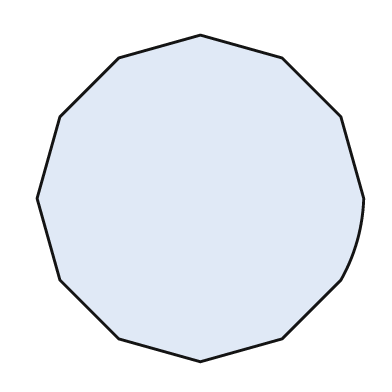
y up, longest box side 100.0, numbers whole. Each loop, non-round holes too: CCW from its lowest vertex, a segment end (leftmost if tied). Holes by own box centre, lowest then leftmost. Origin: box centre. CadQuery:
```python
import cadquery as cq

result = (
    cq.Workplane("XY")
    .moveTo(0.0, -50.0)
    .lineTo(25.0, -43.0)
    .lineTo(43.0, -25.0)
    .threePointArc((48.0, -13.0), (50.0, 0.0))
    .lineTo(43.0, 25.0)
    .lineTo(25.0, 43.0)
    .lineTo(0.0, 50.0)
    .lineTo(-25.0, 43.0)
    .lineTo(-43.0, 25.0)
    .lineTo(-50.0, 0.0)
    .lineTo(-43.0, -25.0)
    .lineTo(-25.0, -43.0)
    .close()
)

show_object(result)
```